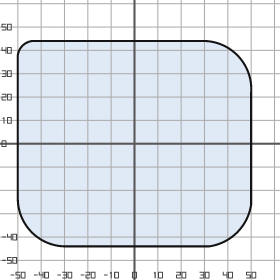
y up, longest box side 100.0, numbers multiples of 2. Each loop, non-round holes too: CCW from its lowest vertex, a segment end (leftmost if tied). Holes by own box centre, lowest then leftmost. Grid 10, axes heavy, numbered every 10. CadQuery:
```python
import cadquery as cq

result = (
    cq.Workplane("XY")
    .moveTo(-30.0, -44.0)
    .lineTo(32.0, -44.0)
    .threePointArc((44.0, -38.0), (50.0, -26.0))
    .lineTo(50.0, 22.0)
    .threePointArc((44.0, 38.0), (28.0, 44.0))
    .lineTo(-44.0, 44.0)
    .threePointArc((-48.0, 42.0), (-50.0, 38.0))
    .lineTo(-50.0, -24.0)
    .threePointArc((-44.0, -38.0), (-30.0, -44.0))
    .close()
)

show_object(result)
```